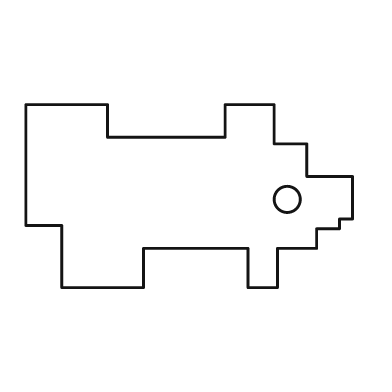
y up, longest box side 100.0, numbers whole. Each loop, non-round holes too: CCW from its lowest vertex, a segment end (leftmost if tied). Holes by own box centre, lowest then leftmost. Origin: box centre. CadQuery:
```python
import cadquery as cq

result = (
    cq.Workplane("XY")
    .moveTo(-39.0, -28.0)
    .lineTo(-14.0, -28.0)
    .lineTo(-14.0, -16.0)
    .lineTo(18.0, -16.0)
    .lineTo(18.0, -28.0)
    .lineTo(27.0, -28.0)
    .lineTo(27.0, -16.0)
    .lineTo(39.0, -16.0)
    .lineTo(39.0, -10.0)
    .lineTo(46.0, -10.0)
    .lineTo(46.0, -7.0)
    .lineTo(50.0, -7.0)
    .lineTo(50.0, 6.0)
    .lineTo(36.0, 6.0)
    .lineTo(36.0, 16.0)
    .lineTo(26.0, 16.0)
    .lineTo(26.0, 28.0)
    .lineTo(11.0, 28.0)
    .lineTo(11.0, 18.0)
    .lineTo(-25.0, 18.0)
    .lineTo(-25.0, 28.0)
    .lineTo(-50.0, 28.0)
    .lineTo(-50.0, -9.0)
    .lineTo(-39.0, -9.0)
    .close()
    .moveTo(30.0, -1.0)
    .circle(4.0)
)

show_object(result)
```